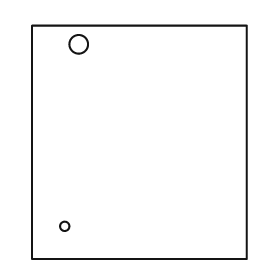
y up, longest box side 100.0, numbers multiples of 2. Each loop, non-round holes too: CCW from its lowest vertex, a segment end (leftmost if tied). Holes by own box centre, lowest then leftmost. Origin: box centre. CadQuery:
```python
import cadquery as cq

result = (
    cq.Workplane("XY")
    .moveTo(-46.0, -50.0)
    .lineTo(46.0, -50.0)
    .lineTo(46.0, 50.0)
    .lineTo(-46.0, 50.0)
    .close()
    .moveTo(-32.0, -36.0)
    .circle(2.0)
    .moveTo(-26.0, 42.0)
    .circle(4.0)
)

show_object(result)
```